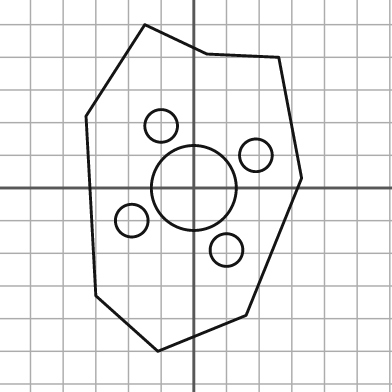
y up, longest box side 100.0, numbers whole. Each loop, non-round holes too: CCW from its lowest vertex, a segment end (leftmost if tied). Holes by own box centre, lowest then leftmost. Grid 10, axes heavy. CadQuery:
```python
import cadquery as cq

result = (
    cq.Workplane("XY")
    .moveTo(-11.0, -50.0)
    .lineTo(16.0, -39.0)
    .lineTo(33.0, 3.0)
    .lineTo(26.0, 40.0)
    .lineTo(4.0, 41.0)
    .lineTo(-15.0, 50.0)
    .lineTo(-33.0, 22.0)
    .lineTo(-30.0, -33.0)
    .close()
    .moveTo(10.0, -19.0)
    .circle(5.0)
    .moveTo(-19.0, -10.0)
    .circle(5.0)
    .moveTo(0.0, 0.0)
    .circle(13.0)
    .moveTo(19.0, 10.0)
    .circle(5.0)
    .moveTo(-10.0, 19.0)
    .circle(5.0)
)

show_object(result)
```